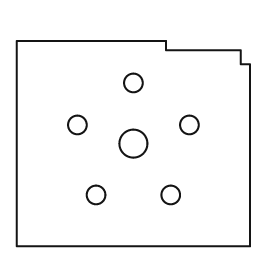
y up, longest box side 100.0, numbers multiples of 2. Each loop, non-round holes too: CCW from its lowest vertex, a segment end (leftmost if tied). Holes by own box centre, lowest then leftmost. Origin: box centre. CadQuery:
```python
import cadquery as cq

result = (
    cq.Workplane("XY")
    .moveTo(-50.0, -44.0)
    .lineTo(50.0, -44.0)
    .lineTo(50.0, 34.0)
    .lineTo(46.0, 34.0)
    .lineTo(46.0, 40.0)
    .lineTo(14.0, 40.0)
    .lineTo(14.0, 44.0)
    .lineTo(-50.0, 44.0)
    .close()
    .moveTo(-16.0, -22.0)
    .circle(4.0)
    .moveTo(16.0, -22.0)
    .circle(4.0)
    .moveTo(0.0, 0.0)
    .circle(6.0)
    .moveTo(-24.0, 8.0)
    .circle(4.0)
    .moveTo(24.0, 8.0)
    .circle(4.0)
    .moveTo(0.0, 26.0)
    .circle(4.0)
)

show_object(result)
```